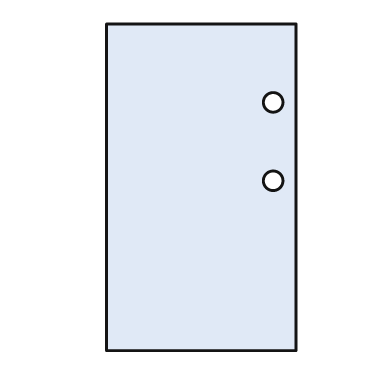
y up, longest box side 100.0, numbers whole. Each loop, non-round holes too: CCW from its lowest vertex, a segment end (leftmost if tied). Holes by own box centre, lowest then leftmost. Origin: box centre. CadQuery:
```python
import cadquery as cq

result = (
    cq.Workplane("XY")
    .moveTo(-29.0, -50.0)
    .lineTo(29.0, -50.0)
    .lineTo(29.0, 50.0)
    .lineTo(-29.0, 50.0)
    .close()
    .moveTo(22.0, 2.0)
    .circle(3.0)
    .moveTo(22.0, 26.0)
    .circle(3.0)
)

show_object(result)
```